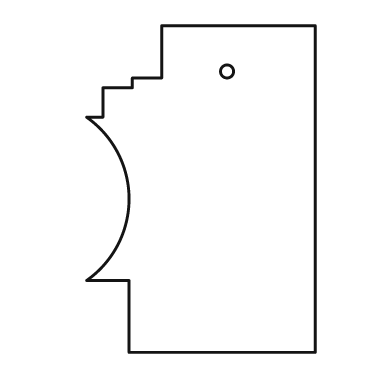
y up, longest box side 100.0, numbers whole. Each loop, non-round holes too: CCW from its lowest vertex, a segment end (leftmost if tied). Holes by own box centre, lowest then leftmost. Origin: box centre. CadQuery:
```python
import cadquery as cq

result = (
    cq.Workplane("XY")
    .moveTo(-22.0, -50.0)
    .lineTo(35.0, -50.0)
    .lineTo(35.0, 50.0)
    .lineTo(-12.0, 50.0)
    .lineTo(-12.0, 34.0)
    .lineTo(-21.0, 34.0)
    .lineTo(-21.0, 31.0)
    .lineTo(-30.0, 31.0)
    .lineTo(-30.0, 22.0)
    .lineTo(-35.0, 22.0)
    .threePointArc((-22.0, -3.0), (-35.0, -28.0))
    .lineTo(-22.0, -28.0)
    .close()
    .moveTo(8.0, 36.0)
    .circle(2.0)
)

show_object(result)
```